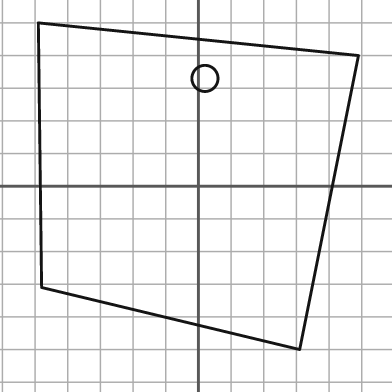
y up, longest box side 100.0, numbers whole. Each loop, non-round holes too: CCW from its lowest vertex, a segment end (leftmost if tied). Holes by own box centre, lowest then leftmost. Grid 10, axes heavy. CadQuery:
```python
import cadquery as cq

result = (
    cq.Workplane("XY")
    .moveTo(31.0, -50.0)
    .lineTo(49.0, 40.0)
    .lineTo(-49.0, 50.0)
    .lineTo(-48.0, -31.0)
    .close()
    .moveTo(2.0, 33.0)
    .circle(4.0)
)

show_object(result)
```